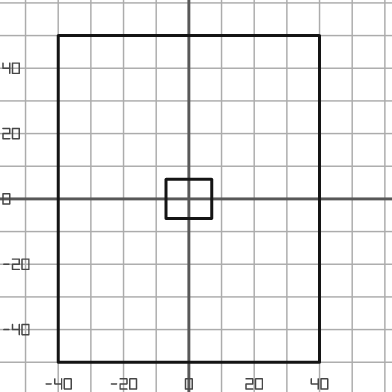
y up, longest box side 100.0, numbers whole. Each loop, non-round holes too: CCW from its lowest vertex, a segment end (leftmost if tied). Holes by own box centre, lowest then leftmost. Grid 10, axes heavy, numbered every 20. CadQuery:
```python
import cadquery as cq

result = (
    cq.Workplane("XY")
    .moveTo(-40.0, -50.0)
    .lineTo(40.0, -50.0)
    .lineTo(40.0, 50.0)
    .lineTo(-40.0, 50.0)
    .close()
    .moveTo(-7.0, -6.0)
    .lineTo(7.0, -6.0)
    .lineTo(7.0, 6.0)
    .lineTo(-7.0, 6.0)
    .close()
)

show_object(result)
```